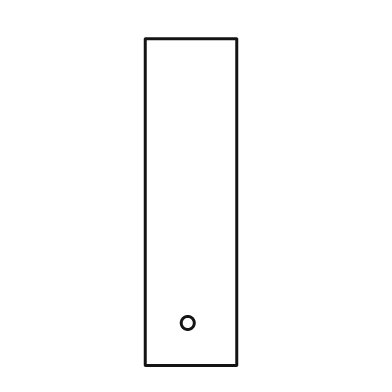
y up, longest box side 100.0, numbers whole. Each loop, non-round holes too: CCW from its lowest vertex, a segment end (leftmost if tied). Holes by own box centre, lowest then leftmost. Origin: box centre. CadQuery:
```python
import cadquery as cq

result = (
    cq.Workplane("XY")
    .moveTo(-14.0, -50.0)
    .lineTo(14.0, -50.0)
    .lineTo(14.0, 50.0)
    .lineTo(-14.0, 50.0)
    .close()
    .moveTo(-1.0, -37.0)
    .circle(2.0)
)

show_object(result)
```